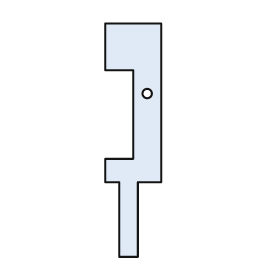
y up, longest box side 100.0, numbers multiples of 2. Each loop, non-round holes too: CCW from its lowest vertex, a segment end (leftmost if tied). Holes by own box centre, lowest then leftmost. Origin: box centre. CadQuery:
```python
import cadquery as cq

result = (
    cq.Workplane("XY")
    .moveTo(-6.0, -50.0)
    .lineTo(2.0, -50.0)
    .lineTo(2.0, -18.0)
    .lineTo(12.0, -18.0)
    .lineTo(12.0, 50.0)
    .lineTo(-12.0, 50.0)
    .lineTo(-12.0, 30.0)
    .lineTo(0.0, 30.0)
    .lineTo(0.0, -8.0)
    .lineTo(-12.0, -8.0)
    .lineTo(-12.0, -18.0)
    .lineTo(-6.0, -18.0)
    .close()
    .moveTo(6.0, 20.0)
    .circle(2.0)
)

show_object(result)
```